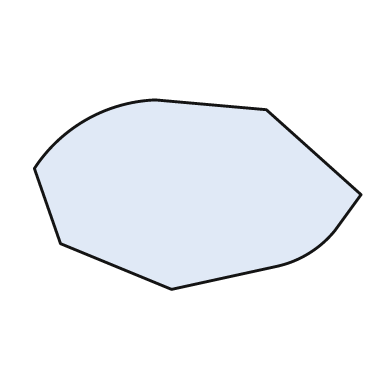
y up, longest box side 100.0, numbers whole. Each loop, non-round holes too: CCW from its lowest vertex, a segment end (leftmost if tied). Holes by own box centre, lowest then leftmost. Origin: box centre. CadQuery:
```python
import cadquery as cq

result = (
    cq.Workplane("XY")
    .moveTo(-8.0, -29.0)
    .lineTo(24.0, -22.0)
    .threePointArc((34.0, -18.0), (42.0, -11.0))
    .lineTo(50.0, 0.0)
    .lineTo(21.0, 26.0)
    .lineTo(-13.0, 29.0)
    .threePointArc((-34.0, 23.0), (-50.0, 8.0))
    .lineTo(-42.0, -15.0)
    .close()
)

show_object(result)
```